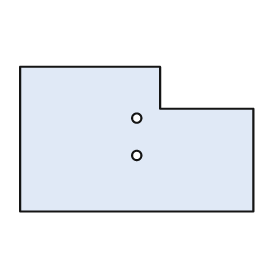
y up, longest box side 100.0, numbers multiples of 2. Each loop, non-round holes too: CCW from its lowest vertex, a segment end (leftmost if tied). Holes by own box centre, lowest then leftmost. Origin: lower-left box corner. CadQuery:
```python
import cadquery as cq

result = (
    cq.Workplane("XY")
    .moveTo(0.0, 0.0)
    .lineTo(100.0, 0.0)
    .lineTo(100.0, 44.0)
    .lineTo(60.0, 44.0)
    .lineTo(60.0, 62.0)
    .lineTo(0.0, 62.0)
    .close()
    .moveTo(50.0, 24.0)
    .circle(2.0)
    .moveTo(50.0, 40.0)
    .circle(2.0)
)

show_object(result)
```